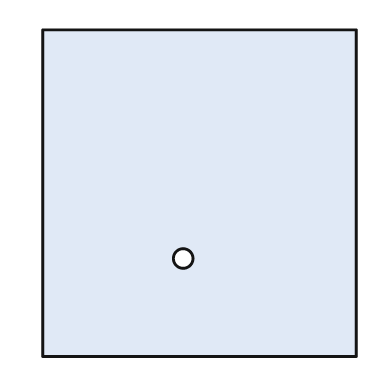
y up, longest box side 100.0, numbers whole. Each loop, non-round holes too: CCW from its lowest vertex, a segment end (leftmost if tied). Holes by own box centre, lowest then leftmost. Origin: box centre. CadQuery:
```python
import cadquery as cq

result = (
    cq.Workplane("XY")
    .moveTo(-48.0, -50.0)
    .lineTo(48.0, -50.0)
    .lineTo(48.0, 50.0)
    .lineTo(-48.0, 50.0)
    .close()
    .moveTo(-5.0, -20.0)
    .circle(3.0)
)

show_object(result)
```